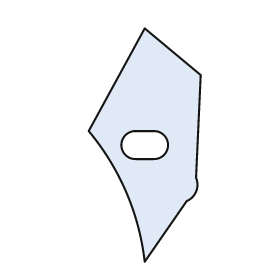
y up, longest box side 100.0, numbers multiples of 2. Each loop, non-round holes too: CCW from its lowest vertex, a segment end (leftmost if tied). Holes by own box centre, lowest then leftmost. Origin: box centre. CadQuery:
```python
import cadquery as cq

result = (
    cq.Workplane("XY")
    .moveTo(0.0, -50.0)
    .lineTo(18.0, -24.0)
    .threePointArc((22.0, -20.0), (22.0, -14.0))
    .lineTo(24.0, 30.0)
    .lineTo(0.0, 50.0)
    .lineTo(-24.0, 6.0)
    .threePointArc((-8.0, -20.0), (0.0, -50.0))
    .close()
    .moveTo(-4.0, -6.0)
    .lineTo(4.0, -6.0)
    .threePointArc((10.0, 0.0), (4.0, 6.0))
    .lineTo(-4.0, 6.0)
    .threePointArc((-10.0, 0.0), (-4.0, -6.0))
    .close()
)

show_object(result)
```